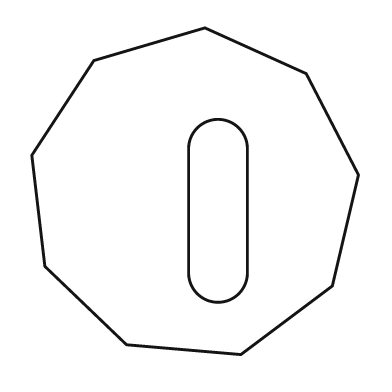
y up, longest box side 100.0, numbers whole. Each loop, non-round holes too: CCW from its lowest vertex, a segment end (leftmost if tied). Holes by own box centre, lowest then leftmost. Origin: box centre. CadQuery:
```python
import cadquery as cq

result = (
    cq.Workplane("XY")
    .moveTo(14.0, -50.0)
    .lineTo(42.0, -29.0)
    .lineTo(50.0, 5.0)
    .lineTo(34.0, 36.0)
    .lineTo(3.0, 50.0)
    .lineTo(-31.0, 40.0)
    .lineTo(-50.0, 11.0)
    .lineTo(-46.0, -23.0)
    .lineTo(-21.0, -47.0)
    .close()
    .moveTo(-2.0, -25.0)
    .threePointArc((7.0, -34.0), (16.0, -25.0))
    .lineTo(16.0, 13.0)
    .threePointArc((7.0, 22.0), (-2.0, 13.0))
    .close()
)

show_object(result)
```